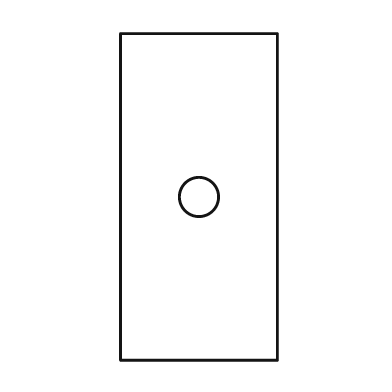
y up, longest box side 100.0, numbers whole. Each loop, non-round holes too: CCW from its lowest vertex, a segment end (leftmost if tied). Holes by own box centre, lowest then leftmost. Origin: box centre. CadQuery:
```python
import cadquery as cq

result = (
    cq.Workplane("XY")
    .moveTo(-24.0, -50.0)
    .lineTo(24.0, -50.0)
    .lineTo(24.0, 50.0)
    .lineTo(-24.0, 50.0)
    .close()
    .moveTo(0.0, 0.0)
    .circle(6.0)
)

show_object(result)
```